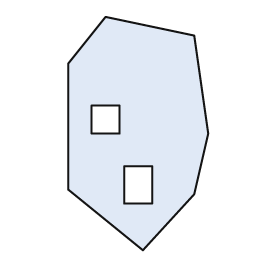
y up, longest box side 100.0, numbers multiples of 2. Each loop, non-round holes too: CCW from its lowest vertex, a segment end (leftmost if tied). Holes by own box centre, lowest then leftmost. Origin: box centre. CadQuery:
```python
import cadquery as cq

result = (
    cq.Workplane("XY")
    .moveTo(2.0, -50.0)
    .lineTo(24.0, -26.0)
    .lineTo(30.0, 0.0)
    .lineTo(24.0, 42.0)
    .lineTo(-14.0, 50.0)
    .lineTo(-30.0, 30.0)
    .lineTo(-30.0, -24.0)
    .close()
    .moveTo(-6.0, -30.0)
    .lineTo(6.0, -30.0)
    .lineTo(6.0, -14.0)
    .lineTo(-6.0, -14.0)
    .close()
    .moveTo(-20.0, 0.0)
    .lineTo(-8.0, 0.0)
    .lineTo(-8.0, 12.0)
    .lineTo(-20.0, 12.0)
    .close()
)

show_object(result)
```